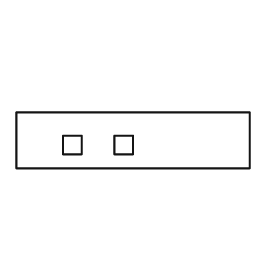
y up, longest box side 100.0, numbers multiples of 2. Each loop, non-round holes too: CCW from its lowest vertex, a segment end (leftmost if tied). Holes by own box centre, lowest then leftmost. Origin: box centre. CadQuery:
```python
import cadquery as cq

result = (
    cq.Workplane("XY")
    .moveTo(-50.0, -12.0)
    .lineTo(50.0, -12.0)
    .lineTo(50.0, 12.0)
    .lineTo(-50.0, 12.0)
    .close()
    .moveTo(-30.0, -6.0)
    .lineTo(-22.0, -6.0)
    .lineTo(-22.0, 2.0)
    .lineTo(-30.0, 2.0)
    .close()
    .moveTo(-8.0, -6.0)
    .lineTo(0.0, -6.0)
    .lineTo(0.0, 2.0)
    .lineTo(-8.0, 2.0)
    .close()
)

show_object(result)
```